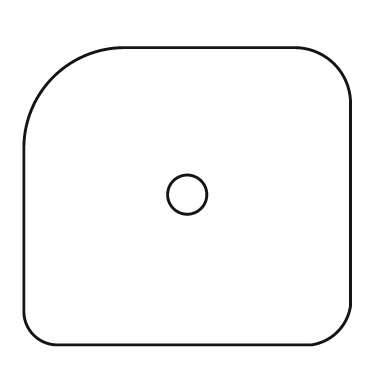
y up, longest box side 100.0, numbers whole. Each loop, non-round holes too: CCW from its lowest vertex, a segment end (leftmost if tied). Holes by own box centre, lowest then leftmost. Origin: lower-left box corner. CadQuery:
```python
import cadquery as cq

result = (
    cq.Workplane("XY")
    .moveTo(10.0, 0.0)
    .lineTo(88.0, 0.0)
    .threePointArc((96.0, 4.0), (100.0, 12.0))
    .lineTo(100.0, 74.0)
    .threePointArc((95.0, 86.0), (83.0, 91.0))
    .lineTo(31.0, 91.0)
    .threePointArc((9.0, 82.0), (0.0, 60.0))
    .lineTo(0.0, 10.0)
    .threePointArc((3.0, 3.0), (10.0, 0.0))
    .close()
    .moveTo(50.0, 46.0)
    .circle(6.0)
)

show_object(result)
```